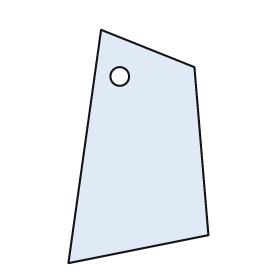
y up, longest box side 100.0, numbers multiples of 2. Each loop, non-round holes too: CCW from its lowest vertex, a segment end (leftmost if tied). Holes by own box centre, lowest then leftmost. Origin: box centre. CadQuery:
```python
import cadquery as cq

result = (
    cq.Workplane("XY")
    .moveTo(-30.0, -50.0)
    .lineTo(30.0, -38.0)
    .lineTo(24.0, 34.0)
    .lineTo(-16.0, 50.0)
    .close()
    .moveTo(-8.0, 30.0)
    .circle(4.0)
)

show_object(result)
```